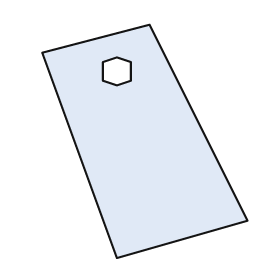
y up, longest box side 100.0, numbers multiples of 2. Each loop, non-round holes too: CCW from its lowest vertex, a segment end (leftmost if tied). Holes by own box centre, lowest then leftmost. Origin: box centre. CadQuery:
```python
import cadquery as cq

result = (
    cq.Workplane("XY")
    .moveTo(-12.0, -50.0)
    .lineTo(44.0, -34.0)
    .lineTo(2.0, 50.0)
    .lineTo(-44.0, 38.0)
    .close()
    .moveTo(-12.0, 24.0)
    .lineTo(-6.0, 26.0)
    .lineTo(-6.0, 34.0)
    .lineTo(-12.0, 36.0)
    .lineTo(-18.0, 34.0)
    .lineTo(-18.0, 26.0)
    .close()
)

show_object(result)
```